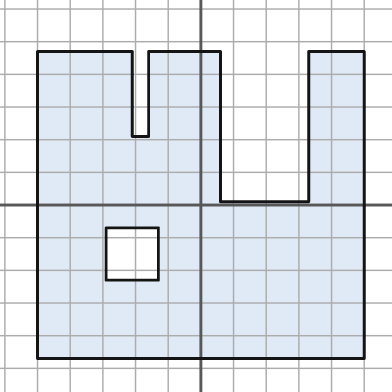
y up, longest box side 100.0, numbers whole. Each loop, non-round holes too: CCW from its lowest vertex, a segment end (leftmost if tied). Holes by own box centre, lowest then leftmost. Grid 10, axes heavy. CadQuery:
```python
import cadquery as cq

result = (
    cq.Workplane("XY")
    .moveTo(-50.0, -47.0)
    .lineTo(50.0, -47.0)
    .lineTo(50.0, 47.0)
    .lineTo(33.0, 47.0)
    .lineTo(33.0, 1.0)
    .lineTo(6.0, 1.0)
    .lineTo(6.0, 47.0)
    .lineTo(-16.0, 47.0)
    .lineTo(-16.0, 21.0)
    .lineTo(-21.0, 21.0)
    .lineTo(-21.0, 47.0)
    .lineTo(-50.0, 47.0)
    .close()
    .moveTo(-29.0, -23.0)
    .lineTo(-13.0, -23.0)
    .lineTo(-13.0, -7.0)
    .lineTo(-29.0, -7.0)
    .close()
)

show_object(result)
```